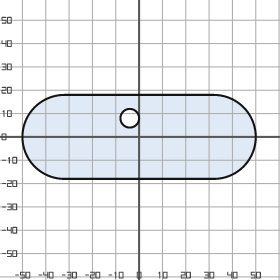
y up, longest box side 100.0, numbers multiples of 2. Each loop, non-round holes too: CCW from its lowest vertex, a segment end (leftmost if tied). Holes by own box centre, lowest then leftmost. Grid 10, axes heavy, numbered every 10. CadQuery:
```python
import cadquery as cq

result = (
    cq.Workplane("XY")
    .moveTo(-32.0, -18.0)
    .lineTo(32.0, -18.0)
    .threePointArc((50.0, 0.0), (32.0, 18.0))
    .lineTo(-32.0, 18.0)
    .threePointArc((-50.0, 0.0), (-32.0, -18.0))
    .close()
    .moveTo(-4.0, 8.0)
    .circle(4.0)
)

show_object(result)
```